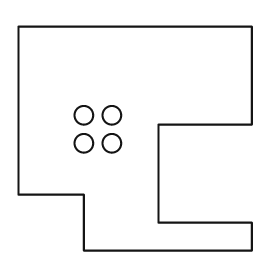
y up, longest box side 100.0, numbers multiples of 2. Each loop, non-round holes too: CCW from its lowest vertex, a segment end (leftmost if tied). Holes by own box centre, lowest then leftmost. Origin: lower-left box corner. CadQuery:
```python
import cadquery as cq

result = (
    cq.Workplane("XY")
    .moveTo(28.0, 0.0)
    .lineTo(100.0, 0.0)
    .lineTo(100.0, 12.0)
    .lineTo(60.0, 12.0)
    .lineTo(60.0, 54.0)
    .lineTo(100.0, 54.0)
    .lineTo(100.0, 96.0)
    .lineTo(0.0, 96.0)
    .lineTo(0.0, 24.0)
    .lineTo(28.0, 24.0)
    .close()
    .moveTo(28.0, 46.0)
    .circle(4.0)
    .moveTo(40.0, 46.0)
    .circle(4.0)
    .moveTo(28.0, 58.0)
    .circle(4.0)
    .moveTo(40.0, 58.0)
    .circle(4.0)
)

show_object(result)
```